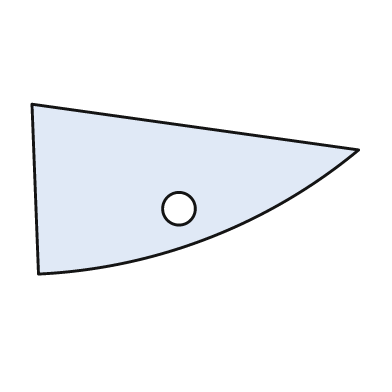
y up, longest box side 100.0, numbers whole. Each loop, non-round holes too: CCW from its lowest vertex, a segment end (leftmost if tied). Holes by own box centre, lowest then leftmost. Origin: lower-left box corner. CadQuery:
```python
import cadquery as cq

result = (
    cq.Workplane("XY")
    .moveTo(2.0, 0.0)
    .threePointArc((54.0, 11.0), (100.0, 38.0))
    .lineTo(0.0, 52.0)
    .close()
    .moveTo(45.0, 20.0)
    .circle(5.0)
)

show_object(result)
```